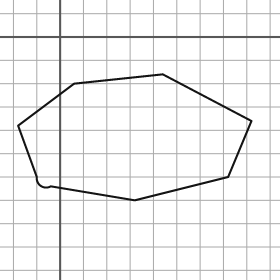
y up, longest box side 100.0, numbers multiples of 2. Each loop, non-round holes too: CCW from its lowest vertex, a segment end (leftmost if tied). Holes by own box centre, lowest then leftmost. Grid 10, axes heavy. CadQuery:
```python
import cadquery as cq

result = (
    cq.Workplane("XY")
    .moveTo(32.0, -70.0)
    .lineTo(72.0, -60.0)
    .lineTo(82.0, -36.0)
    .lineTo(44.0, -16.0)
    .lineTo(6.0, -20.0)
    .lineTo(-18.0, -38.0)
    .lineTo(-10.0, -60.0)
    .threePointArc((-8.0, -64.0), (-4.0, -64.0))
    .close()
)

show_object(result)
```